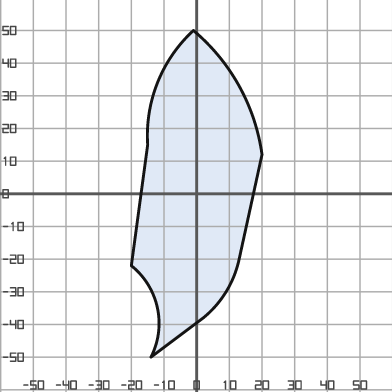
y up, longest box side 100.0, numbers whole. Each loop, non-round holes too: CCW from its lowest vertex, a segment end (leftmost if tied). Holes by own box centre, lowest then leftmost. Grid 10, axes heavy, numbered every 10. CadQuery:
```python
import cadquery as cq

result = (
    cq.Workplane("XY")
    .moveTo(-14.0, -50.0)
    .lineTo(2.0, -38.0)
    .threePointArc((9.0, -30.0), (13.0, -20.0))
    .lineTo(20.0, 12.0)
    .threePointArc((13.0, 33.0), (-1.0, 50.0))
    .threePointArc((-12.0, 34.0), (-15.0, 15.0))
    .lineTo(-20.0, -22.0)
    .threePointArc((-12.0, -35.0), (-14.0, -50.0))
    .close()
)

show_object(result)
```